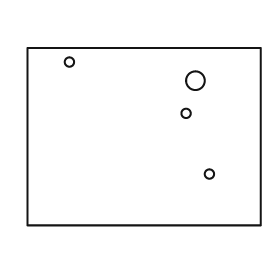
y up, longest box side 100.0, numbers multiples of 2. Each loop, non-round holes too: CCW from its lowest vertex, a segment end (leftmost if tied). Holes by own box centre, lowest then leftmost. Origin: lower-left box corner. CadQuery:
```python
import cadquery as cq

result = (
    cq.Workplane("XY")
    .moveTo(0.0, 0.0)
    .lineTo(100.0, 0.0)
    .lineTo(100.0, 76.0)
    .lineTo(0.0, 76.0)
    .close()
    .moveTo(78.0, 22.0)
    .circle(2.0)
    .moveTo(68.0, 48.0)
    .circle(2.0)
    .moveTo(72.0, 62.0)
    .circle(4.0)
    .moveTo(18.0, 70.0)
    .circle(2.0)
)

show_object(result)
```